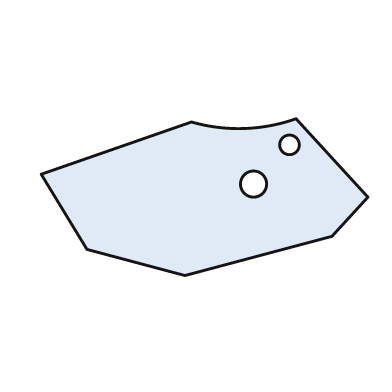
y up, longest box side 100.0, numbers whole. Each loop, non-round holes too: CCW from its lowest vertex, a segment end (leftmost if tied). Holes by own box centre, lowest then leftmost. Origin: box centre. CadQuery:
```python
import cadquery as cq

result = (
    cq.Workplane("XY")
    .moveTo(-6.0, -24.0)
    .lineTo(39.0, -12.0)
    .lineTo(50.0, 0.0)
    .lineTo(28.0, 24.0)
    .threePointArc((12.0, 21.0), (-4.0, 23.0))
    .lineTo(-50.0, 7.0)
    .lineTo(-36.0, -16.0)
    .close()
    .moveTo(15.0, 4.0)
    .circle(4.0)
    .moveTo(26.0, 16.0)
    .circle(3.0)
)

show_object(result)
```